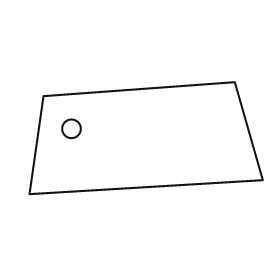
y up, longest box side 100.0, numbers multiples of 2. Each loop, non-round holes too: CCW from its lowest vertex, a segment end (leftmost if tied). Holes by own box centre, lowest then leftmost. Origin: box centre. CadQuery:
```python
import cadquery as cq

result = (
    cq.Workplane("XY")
    .moveTo(-50.0, -24.0)
    .lineTo(50.0, -18.0)
    .lineTo(38.0, 24.0)
    .lineTo(-44.0, 18.0)
    .close()
    .moveTo(-32.0, 4.0)
    .circle(4.0)
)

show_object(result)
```